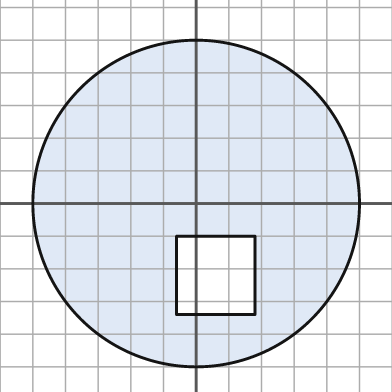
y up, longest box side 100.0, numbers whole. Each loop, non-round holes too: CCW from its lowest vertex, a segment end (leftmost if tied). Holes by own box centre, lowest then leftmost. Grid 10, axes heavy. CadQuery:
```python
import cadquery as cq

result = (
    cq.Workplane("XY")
    .moveTo(0.0, 0.0)
    .circle(50.0)
    .moveTo(-6.0, -34.0)
    .lineTo(18.0, -34.0)
    .lineTo(18.0, -10.0)
    .lineTo(-6.0, -10.0)
    .close()
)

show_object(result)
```